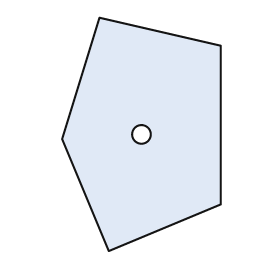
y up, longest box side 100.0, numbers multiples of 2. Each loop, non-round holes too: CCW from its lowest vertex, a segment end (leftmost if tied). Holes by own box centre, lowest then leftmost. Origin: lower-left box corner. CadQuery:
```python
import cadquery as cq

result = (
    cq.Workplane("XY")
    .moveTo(20.0, 0.0)
    .lineTo(68.0, 20.0)
    .lineTo(68.0, 88.0)
    .lineTo(16.0, 100.0)
    .lineTo(0.0, 48.0)
    .close()
    .moveTo(34.0, 50.0)
    .circle(4.0)
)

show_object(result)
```